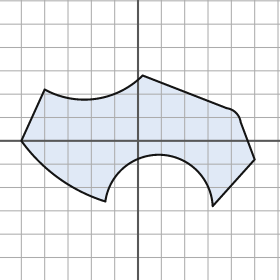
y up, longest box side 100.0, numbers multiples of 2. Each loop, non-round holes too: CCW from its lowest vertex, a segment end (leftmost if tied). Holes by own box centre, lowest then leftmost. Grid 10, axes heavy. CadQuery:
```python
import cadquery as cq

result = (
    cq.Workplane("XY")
    .moveTo(32.0, -28.0)
    .lineTo(50.0, -8.0)
    .lineTo(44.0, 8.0)
    .threePointArc((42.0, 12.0), (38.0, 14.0))
    .lineTo(2.0, 28.0)
    .threePointArc((-18.0, 18.0), (-40.0, 22.0))
    .lineTo(-50.0, 0.0)
    .threePointArc((-34.0, -16.0), (-14.0, -26.0))
    .threePointArc((10.0, -6.0), (32.0, -28.0))
    .close()
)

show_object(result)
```